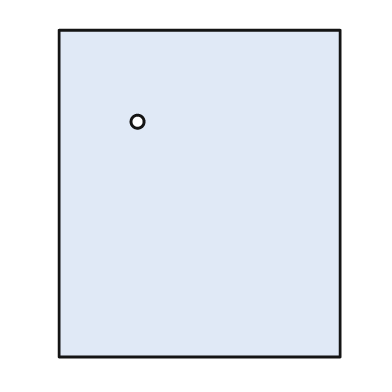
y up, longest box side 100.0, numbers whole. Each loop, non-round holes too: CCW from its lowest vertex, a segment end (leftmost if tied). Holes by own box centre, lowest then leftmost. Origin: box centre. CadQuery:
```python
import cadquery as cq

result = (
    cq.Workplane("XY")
    .moveTo(-43.0, -50.0)
    .lineTo(43.0, -50.0)
    .lineTo(43.0, 50.0)
    .lineTo(-43.0, 50.0)
    .close()
    .moveTo(-19.0, 22.0)
    .circle(2.0)
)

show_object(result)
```